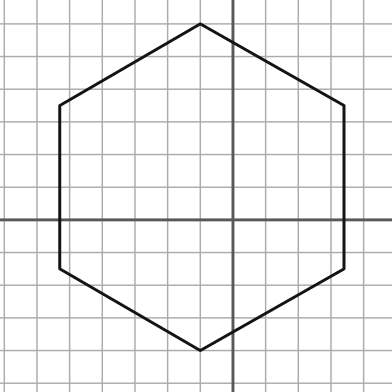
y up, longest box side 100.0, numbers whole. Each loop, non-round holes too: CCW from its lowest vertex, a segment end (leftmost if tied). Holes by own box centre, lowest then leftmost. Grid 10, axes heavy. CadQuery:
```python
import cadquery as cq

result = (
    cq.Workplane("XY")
    .moveTo(-10.0, -40.0)
    .lineTo(34.0, -15.0)
    .lineTo(34.0, 35.0)
    .lineTo(-10.0, 60.0)
    .lineTo(-53.0, 35.0)
    .lineTo(-53.0, -15.0)
    .close()
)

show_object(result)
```